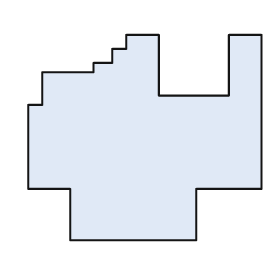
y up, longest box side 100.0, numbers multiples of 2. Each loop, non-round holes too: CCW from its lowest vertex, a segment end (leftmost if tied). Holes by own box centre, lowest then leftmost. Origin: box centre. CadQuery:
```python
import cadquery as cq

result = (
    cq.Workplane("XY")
    .moveTo(-32.0, -44.0)
    .lineTo(22.0, -44.0)
    .lineTo(22.0, -22.0)
    .lineTo(50.0, -22.0)
    .lineTo(50.0, 44.0)
    .lineTo(36.0, 44.0)
    .lineTo(36.0, 18.0)
    .lineTo(6.0, 18.0)
    .lineTo(6.0, 44.0)
    .lineTo(-8.0, 44.0)
    .lineTo(-8.0, 38.0)
    .lineTo(-14.0, 38.0)
    .lineTo(-14.0, 32.0)
    .lineTo(-22.0, 32.0)
    .lineTo(-22.0, 28.0)
    .lineTo(-44.0, 28.0)
    .lineTo(-44.0, 14.0)
    .lineTo(-50.0, 14.0)
    .lineTo(-50.0, -22.0)
    .lineTo(-32.0, -22.0)
    .close()
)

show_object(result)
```